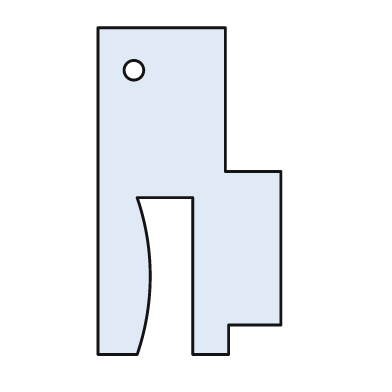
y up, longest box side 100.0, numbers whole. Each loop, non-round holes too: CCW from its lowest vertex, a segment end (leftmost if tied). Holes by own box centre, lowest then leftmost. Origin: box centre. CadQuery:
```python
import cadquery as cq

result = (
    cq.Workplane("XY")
    .moveTo(-28.0, -50.0)
    .lineTo(-16.0, -50.0)
    .threePointArc((-12.0, -26.0), (-16.0, -2.0))
    .lineTo(1.0, -2.0)
    .lineTo(1.0, -50.0)
    .lineTo(12.0, -50.0)
    .lineTo(12.0, -41.0)
    .lineTo(28.0, -41.0)
    .lineTo(28.0, 6.0)
    .lineTo(11.0, 6.0)
    .lineTo(11.0, 50.0)
    .lineTo(-28.0, 50.0)
    .close()
    .moveTo(-17.0, 37.0)
    .circle(3.0)
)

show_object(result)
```